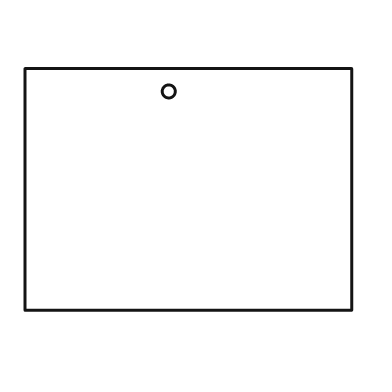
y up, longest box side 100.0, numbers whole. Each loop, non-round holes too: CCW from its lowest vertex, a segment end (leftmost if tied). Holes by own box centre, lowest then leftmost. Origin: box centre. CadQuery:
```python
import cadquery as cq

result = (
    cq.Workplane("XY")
    .moveTo(-50.0, -37.0)
    .lineTo(50.0, -37.0)
    .lineTo(50.0, 37.0)
    .lineTo(-50.0, 37.0)
    .close()
    .moveTo(-6.0, 30.0)
    .circle(2.0)
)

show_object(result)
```